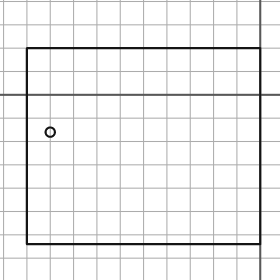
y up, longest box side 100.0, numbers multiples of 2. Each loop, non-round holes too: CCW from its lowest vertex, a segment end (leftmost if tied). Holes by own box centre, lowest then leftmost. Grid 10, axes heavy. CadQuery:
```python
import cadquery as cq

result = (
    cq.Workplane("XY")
    .moveTo(-100.0, -64.0)
    .lineTo(0.0, -64.0)
    .lineTo(0.0, 20.0)
    .lineTo(-100.0, 20.0)
    .close()
    .moveTo(-90.0, -16.0)
    .circle(2.0)
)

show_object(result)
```